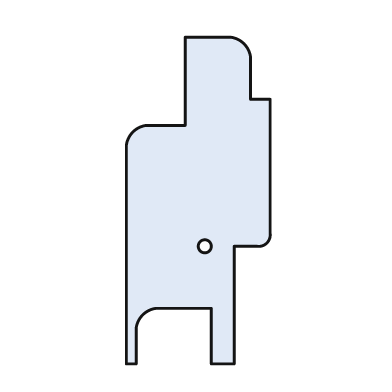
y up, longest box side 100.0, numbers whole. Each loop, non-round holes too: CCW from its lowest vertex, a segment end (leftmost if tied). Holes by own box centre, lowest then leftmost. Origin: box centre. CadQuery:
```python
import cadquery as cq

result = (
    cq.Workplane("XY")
    .moveTo(-22.0, -50.0)
    .lineTo(-19.0, -50.0)
    .lineTo(-19.0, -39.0)
    .threePointArc((-17.0, -35.0), (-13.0, -33.0))
    .lineTo(4.0, -33.0)
    .lineTo(4.0, -50.0)
    .lineTo(11.0, -50.0)
    .lineTo(11.0, -14.0)
    .lineTo(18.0, -14.0)
    .threePointArc((21.0, -13.0), (22.0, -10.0))
    .lineTo(22.0, 31.0)
    .lineTo(16.0, 31.0)
    .lineTo(16.0, 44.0)
    .threePointArc((14.0, 48.0), (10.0, 50.0))
    .lineTo(-4.0, 50.0)
    .lineTo(-4.0, 23.0)
    .lineTo(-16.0, 23.0)
    .threePointArc((-20.0, 21.0), (-22.0, 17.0))
    .close()
    .moveTo(2.0, -14.0)
    .circle(2.0)
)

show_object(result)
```